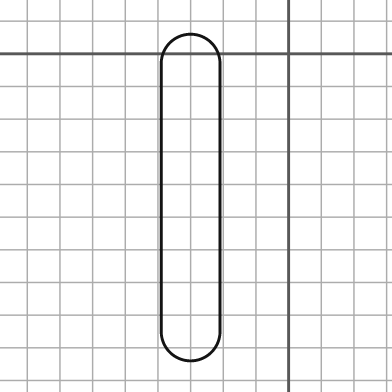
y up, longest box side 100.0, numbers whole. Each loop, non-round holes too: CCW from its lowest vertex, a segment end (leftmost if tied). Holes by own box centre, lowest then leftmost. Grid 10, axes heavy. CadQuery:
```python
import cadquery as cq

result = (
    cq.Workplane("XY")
    .moveTo(-39.0, -85.0)
    .threePointArc((-30.0, -94.0), (-21.0, -85.0))
    .lineTo(-21.0, -3.0)
    .threePointArc((-30.0, 6.0), (-39.0, -3.0))
    .close()
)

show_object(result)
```